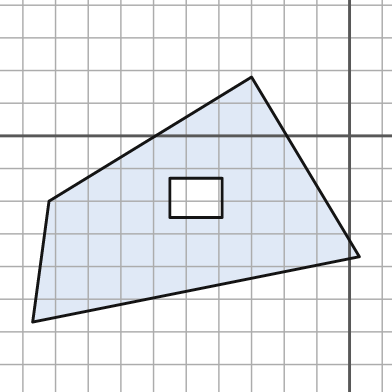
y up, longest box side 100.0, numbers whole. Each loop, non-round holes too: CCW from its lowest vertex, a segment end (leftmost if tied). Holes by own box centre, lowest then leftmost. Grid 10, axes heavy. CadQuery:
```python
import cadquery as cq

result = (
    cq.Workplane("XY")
    .moveTo(-97.0, -57.0)
    .lineTo(3.0, -37.0)
    .lineTo(-30.0, 18.0)
    .lineTo(-92.0, -20.0)
    .close()
    .moveTo(-55.0, -25.0)
    .lineTo(-39.0, -25.0)
    .lineTo(-39.0, -13.0)
    .lineTo(-55.0, -13.0)
    .close()
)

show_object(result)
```